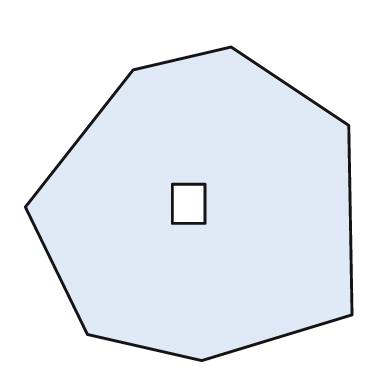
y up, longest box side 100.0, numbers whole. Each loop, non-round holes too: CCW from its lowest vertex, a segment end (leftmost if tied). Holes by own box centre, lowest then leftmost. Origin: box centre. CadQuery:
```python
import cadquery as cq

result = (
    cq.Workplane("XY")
    .moveTo(4.0, -48.0)
    .lineTo(50.0, -34.0)
    .lineTo(49.0, 24.0)
    .lineTo(13.0, 48.0)
    .lineTo(-17.0, 41.0)
    .lineTo(-50.0, -1.0)
    .lineTo(-31.0, -40.0)
    .close()
    .moveTo(-5.0, -6.0)
    .lineTo(5.0, -6.0)
    .lineTo(5.0, 6.0)
    .lineTo(-5.0, 6.0)
    .close()
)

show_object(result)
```